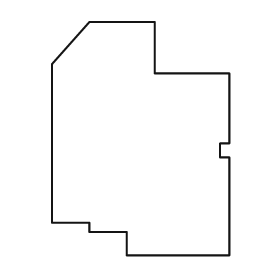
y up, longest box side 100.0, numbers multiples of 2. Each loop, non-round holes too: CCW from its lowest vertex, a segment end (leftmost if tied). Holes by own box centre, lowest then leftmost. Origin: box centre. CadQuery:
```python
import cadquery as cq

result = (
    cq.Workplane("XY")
    .moveTo(-6.0, -50.0)
    .lineTo(38.0, -50.0)
    .lineTo(38.0, -8.0)
    .lineTo(34.0, -8.0)
    .lineTo(34.0, -2.0)
    .lineTo(38.0, -2.0)
    .lineTo(38.0, 28.0)
    .lineTo(6.0, 28.0)
    .lineTo(6.0, 50.0)
    .lineTo(-22.0, 50.0)
    .lineTo(-38.0, 32.0)
    .lineTo(-38.0, -36.0)
    .lineTo(-22.0, -36.0)
    .lineTo(-22.0, -40.0)
    .lineTo(-6.0, -40.0)
    .close()
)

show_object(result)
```